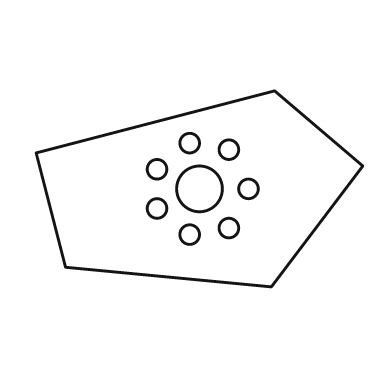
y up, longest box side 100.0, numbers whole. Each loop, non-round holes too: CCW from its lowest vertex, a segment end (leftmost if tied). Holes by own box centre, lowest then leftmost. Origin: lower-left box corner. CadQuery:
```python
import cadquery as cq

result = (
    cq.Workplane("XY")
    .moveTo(72.0, 0.0)
    .lineTo(100.0, 37.0)
    .lineTo(73.0, 60.0)
    .lineTo(0.0, 41.0)
    .lineTo(9.0, 6.0)
    .close()
    .moveTo(47.0, 16.0)
    .circle(3.0)
    .moveTo(59.0, 18.0)
    .circle(3.0)
    .moveTo(37.0, 24.0)
    .circle(3.0)
    .moveTo(50.0, 30.0)
    .circle(7.0)
    .moveTo(65.0, 30.0)
    .circle(3.0)
    .moveTo(37.0, 36.0)
    .circle(3.0)
    .moveTo(59.0, 42.0)
    .circle(3.0)
    .moveTo(47.0, 44.0)
    .circle(3.0)
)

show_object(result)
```